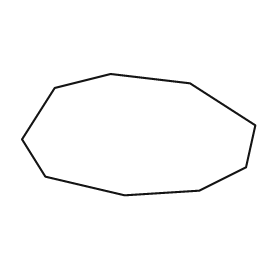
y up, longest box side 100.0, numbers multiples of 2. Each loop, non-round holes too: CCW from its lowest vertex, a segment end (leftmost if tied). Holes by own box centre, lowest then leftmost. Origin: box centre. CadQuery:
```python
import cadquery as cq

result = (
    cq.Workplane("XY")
    .moveTo(-6.0, -26.0)
    .lineTo(26.0, -24.0)
    .lineTo(46.0, -14.0)
    .lineTo(50.0, 4.0)
    .lineTo(22.0, 22.0)
    .lineTo(-12.0, 26.0)
    .lineTo(-36.0, 20.0)
    .lineTo(-50.0, -2.0)
    .lineTo(-40.0, -18.0)
    .close()
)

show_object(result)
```